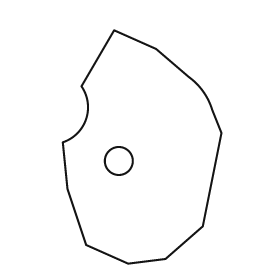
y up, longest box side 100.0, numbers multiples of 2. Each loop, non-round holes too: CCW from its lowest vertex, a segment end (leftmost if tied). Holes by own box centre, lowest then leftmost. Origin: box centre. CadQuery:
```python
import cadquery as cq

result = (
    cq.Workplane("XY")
    .moveTo(-6.0, -50.0)
    .lineTo(10.0, -48.0)
    .lineTo(26.0, -34.0)
    .lineTo(34.0, 6.0)
    .lineTo(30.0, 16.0)
    .threePointArc((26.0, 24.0), (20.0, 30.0))
    .lineTo(6.0, 42.0)
    .lineTo(-12.0, 50.0)
    .lineTo(-26.0, 26.0)
    .threePointArc((-24.0, 12.0), (-34.0, 2.0))
    .lineTo(-32.0, -18.0)
    .lineTo(-24.0, -42.0)
    .close()
    .moveTo(-10.0, -6.0)
    .circle(6.0)
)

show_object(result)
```